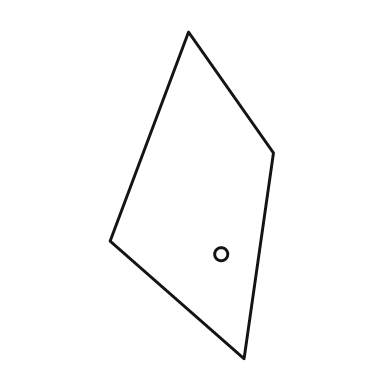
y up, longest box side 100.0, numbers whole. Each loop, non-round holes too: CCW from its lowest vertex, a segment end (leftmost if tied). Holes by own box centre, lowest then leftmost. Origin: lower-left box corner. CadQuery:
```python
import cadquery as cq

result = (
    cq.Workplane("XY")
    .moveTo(41.0, 0.0)
    .lineTo(50.0, 63.0)
    .lineTo(24.0, 100.0)
    .lineTo(0.0, 36.0)
    .close()
    .moveTo(34.0, 32.0)
    .circle(2.0)
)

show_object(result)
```